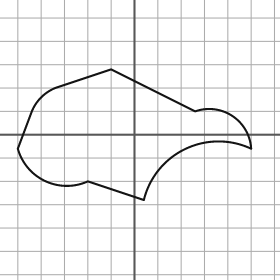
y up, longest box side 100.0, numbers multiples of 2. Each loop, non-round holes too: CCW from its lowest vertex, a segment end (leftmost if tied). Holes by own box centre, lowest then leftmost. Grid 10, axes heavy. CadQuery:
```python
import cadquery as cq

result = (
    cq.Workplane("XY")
    .moveTo(4.0, -28.0)
    .threePointArc((22.0, -6.0), (50.0, -6.0))
    .threePointArc((42.0, 8.0), (26.0, 10.0))
    .lineTo(-10.0, 28.0)
    .lineTo(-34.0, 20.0)
    .threePointArc((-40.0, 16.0), (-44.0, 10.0))
    .lineTo(-50.0, -6.0)
    .threePointArc((-38.0, -20.0), (-20.0, -20.0))
    .close()
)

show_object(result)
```